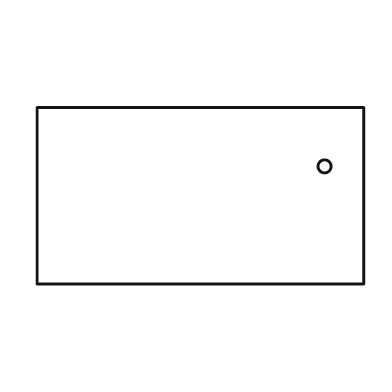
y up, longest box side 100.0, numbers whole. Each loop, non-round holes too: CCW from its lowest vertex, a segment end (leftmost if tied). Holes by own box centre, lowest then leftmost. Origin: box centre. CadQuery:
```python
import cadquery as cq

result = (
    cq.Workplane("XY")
    .moveTo(-50.0, -27.0)
    .lineTo(50.0, -27.0)
    .lineTo(50.0, 27.0)
    .lineTo(-50.0, 27.0)
    .close()
    .moveTo(38.0, 9.0)
    .circle(2.0)
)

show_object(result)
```